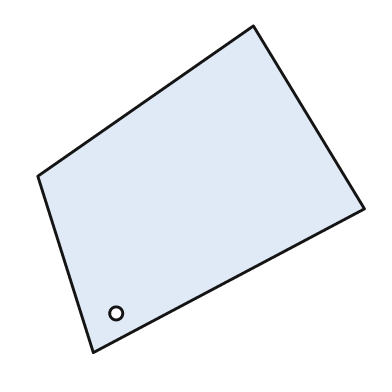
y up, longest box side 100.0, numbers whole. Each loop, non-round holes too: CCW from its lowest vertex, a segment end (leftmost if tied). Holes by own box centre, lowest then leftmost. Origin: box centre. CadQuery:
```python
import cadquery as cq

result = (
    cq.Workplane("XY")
    .moveTo(-33.0, -50.0)
    .lineTo(50.0, -6.0)
    .lineTo(16.0, 50.0)
    .lineTo(-50.0, 4.0)
    .close()
    .moveTo(-26.0, -38.0)
    .circle(2.0)
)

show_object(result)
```